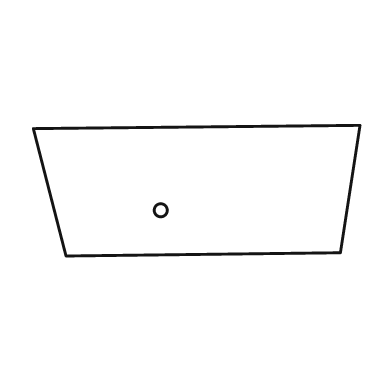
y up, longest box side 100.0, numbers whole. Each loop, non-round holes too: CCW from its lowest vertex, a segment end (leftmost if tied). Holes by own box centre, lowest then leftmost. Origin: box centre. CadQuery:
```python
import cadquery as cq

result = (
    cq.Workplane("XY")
    .moveTo(-40.0, -20.0)
    .lineTo(44.0, -19.0)
    .lineTo(50.0, 20.0)
    .lineTo(-50.0, 19.0)
    .close()
    .moveTo(-11.0, -6.0)
    .circle(2.0)
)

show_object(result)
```